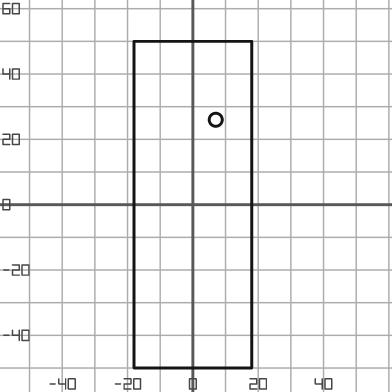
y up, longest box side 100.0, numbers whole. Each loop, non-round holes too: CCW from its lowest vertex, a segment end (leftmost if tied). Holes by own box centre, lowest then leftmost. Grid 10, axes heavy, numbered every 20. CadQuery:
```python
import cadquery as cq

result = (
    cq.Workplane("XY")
    .moveTo(-18.0, -50.0)
    .lineTo(18.0, -50.0)
    .lineTo(18.0, 50.0)
    .lineTo(-18.0, 50.0)
    .close()
    .moveTo(7.0, 26.0)
    .circle(2.0)
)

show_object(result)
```